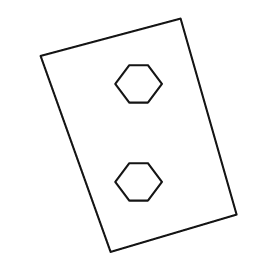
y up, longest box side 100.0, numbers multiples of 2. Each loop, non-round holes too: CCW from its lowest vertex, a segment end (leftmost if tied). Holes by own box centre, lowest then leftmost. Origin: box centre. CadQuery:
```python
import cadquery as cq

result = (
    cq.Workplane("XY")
    .moveTo(-12.0, -50.0)
    .lineTo(42.0, -34.0)
    .lineTo(18.0, 50.0)
    .lineTo(-42.0, 34.0)
    .close()
    .moveTo(-4.0, -28.0)
    .lineTo(4.0, -28.0)
    .lineTo(10.0, -20.0)
    .lineTo(4.0, -12.0)
    .lineTo(-4.0, -12.0)
    .lineTo(-10.0, -20.0)
    .close()
    .moveTo(-4.0, 14.0)
    .lineTo(4.0, 14.0)
    .lineTo(10.0, 22.0)
    .lineTo(4.0, 30.0)
    .lineTo(-4.0, 30.0)
    .lineTo(-10.0, 22.0)
    .close()
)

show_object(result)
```